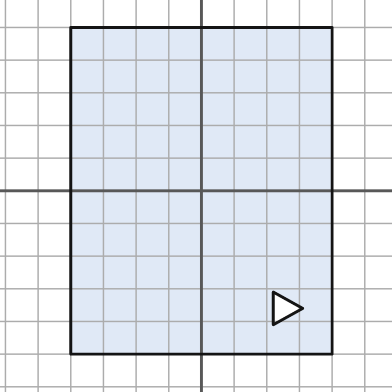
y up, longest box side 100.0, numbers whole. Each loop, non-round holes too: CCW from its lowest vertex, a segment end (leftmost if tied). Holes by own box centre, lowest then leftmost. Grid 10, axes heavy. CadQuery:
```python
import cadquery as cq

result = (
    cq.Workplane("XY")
    .moveTo(-40.0, -50.0)
    .lineTo(40.0, -50.0)
    .lineTo(40.0, 50.0)
    .lineTo(-40.0, 50.0)
    .close()
    .moveTo(22.0, -41.0)
    .lineTo(31.0, -36.0)
    .lineTo(22.0, -31.0)
    .close()
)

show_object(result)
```